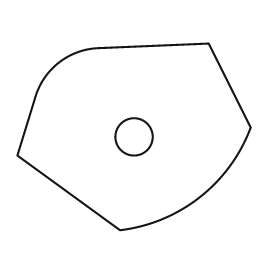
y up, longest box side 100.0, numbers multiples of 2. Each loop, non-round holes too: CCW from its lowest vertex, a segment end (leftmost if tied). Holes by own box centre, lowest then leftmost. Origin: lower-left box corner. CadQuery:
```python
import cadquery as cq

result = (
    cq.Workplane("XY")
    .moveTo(44.0, 0.0)
    .threePointArc((78.0, 14.0), (100.0, 44.0))
    .lineTo(82.0, 80.0)
    .lineTo(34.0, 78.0)
    .threePointArc((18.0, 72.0), (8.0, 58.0))
    .lineTo(0.0, 32.0)
    .close()
    .moveTo(50.0, 40.0)
    .circle(8.0)
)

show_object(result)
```